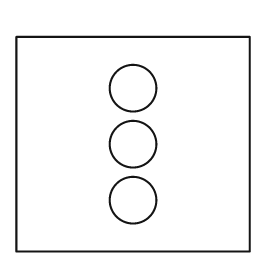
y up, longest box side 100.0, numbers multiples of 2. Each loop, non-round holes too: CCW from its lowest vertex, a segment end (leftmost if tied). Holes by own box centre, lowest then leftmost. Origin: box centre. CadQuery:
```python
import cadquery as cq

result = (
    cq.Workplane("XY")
    .moveTo(-50.0, -46.0)
    .lineTo(50.0, -46.0)
    .lineTo(50.0, 46.0)
    .lineTo(-50.0, 46.0)
    .close()
    .moveTo(0.0, -24.0)
    .circle(10.0)
    .moveTo(0.0, 0.0)
    .circle(10.0)
    .moveTo(0.0, 24.0)
    .circle(10.0)
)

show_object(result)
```